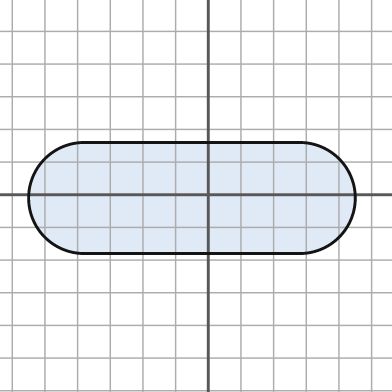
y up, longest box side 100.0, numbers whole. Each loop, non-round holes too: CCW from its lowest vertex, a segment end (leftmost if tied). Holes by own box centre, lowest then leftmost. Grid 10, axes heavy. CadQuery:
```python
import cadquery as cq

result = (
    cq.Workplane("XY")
    .moveTo(-38.0, -18.0)
    .lineTo(28.0, -18.0)
    .threePointArc((45.0, -1.0), (28.0, 16.0))
    .lineTo(-38.0, 16.0)
    .threePointArc((-55.0, -1.0), (-38.0, -18.0))
    .close()
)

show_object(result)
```